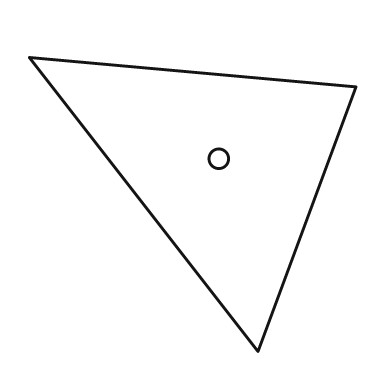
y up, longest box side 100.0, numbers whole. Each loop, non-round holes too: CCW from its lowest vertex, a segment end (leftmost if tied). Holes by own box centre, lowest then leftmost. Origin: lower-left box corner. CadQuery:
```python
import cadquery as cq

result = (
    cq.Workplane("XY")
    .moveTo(70.0, 0.0)
    .lineTo(100.0, 81.0)
    .lineTo(0.0, 90.0)
    .close()
    .moveTo(58.0, 59.0)
    .circle(3.0)
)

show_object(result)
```